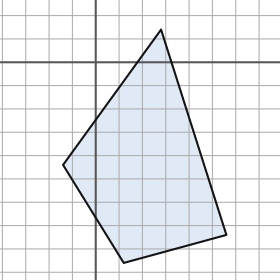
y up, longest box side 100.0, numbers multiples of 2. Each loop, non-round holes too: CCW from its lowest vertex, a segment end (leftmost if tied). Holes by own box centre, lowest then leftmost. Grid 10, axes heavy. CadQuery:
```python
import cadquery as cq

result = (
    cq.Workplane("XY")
    .moveTo(12.0, -86.0)
    .lineTo(56.0, -74.0)
    .lineTo(28.0, 14.0)
    .lineTo(-14.0, -44.0)
    .close()
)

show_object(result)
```